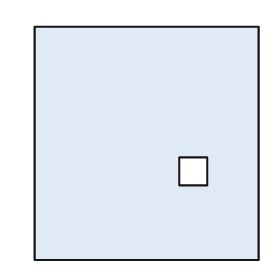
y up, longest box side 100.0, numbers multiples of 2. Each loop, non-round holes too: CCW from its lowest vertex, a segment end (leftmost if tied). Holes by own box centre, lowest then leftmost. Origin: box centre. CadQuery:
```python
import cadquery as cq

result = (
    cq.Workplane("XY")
    .moveTo(-48.0, -50.0)
    .lineTo(48.0, -50.0)
    .lineTo(48.0, 50.0)
    .lineTo(-48.0, 50.0)
    .close()
    .moveTo(14.0, -18.0)
    .lineTo(26.0, -18.0)
    .lineTo(26.0, -6.0)
    .lineTo(14.0, -6.0)
    .close()
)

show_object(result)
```